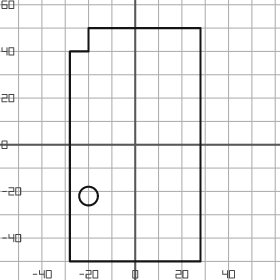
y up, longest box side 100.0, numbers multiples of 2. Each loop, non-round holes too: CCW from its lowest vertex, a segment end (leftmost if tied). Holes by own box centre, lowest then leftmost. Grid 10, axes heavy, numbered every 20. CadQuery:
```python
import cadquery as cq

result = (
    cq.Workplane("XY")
    .moveTo(-28.0, -50.0)
    .lineTo(28.0, -50.0)
    .lineTo(28.0, 50.0)
    .lineTo(-20.0, 50.0)
    .lineTo(-20.0, 40.0)
    .lineTo(-28.0, 40.0)
    .close()
    .moveTo(-20.0, -22.0)
    .circle(4.0)
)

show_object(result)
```